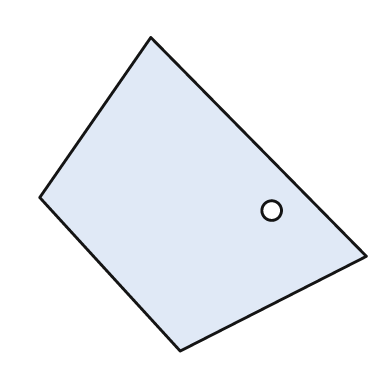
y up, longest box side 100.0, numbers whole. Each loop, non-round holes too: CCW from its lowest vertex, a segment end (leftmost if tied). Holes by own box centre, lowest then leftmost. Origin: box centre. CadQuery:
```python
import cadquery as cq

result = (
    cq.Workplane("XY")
    .moveTo(-7.0, -48.0)
    .lineTo(50.0, -19.0)
    .lineTo(-16.0, 48.0)
    .lineTo(-50.0, -1.0)
    .close()
    .moveTo(21.0, -5.0)
    .circle(3.0)
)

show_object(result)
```